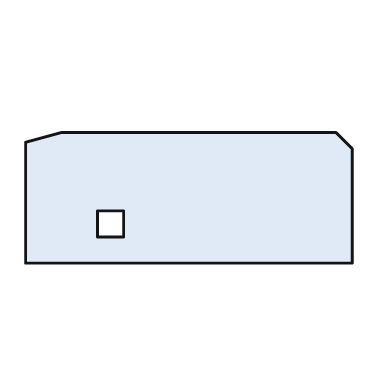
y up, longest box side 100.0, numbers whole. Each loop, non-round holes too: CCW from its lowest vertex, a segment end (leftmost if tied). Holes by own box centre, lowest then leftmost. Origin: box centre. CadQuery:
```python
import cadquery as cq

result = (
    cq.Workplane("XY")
    .moveTo(-50.0, -20.0)
    .lineTo(50.0, -20.0)
    .lineTo(50.0, 15.0)
    .lineTo(45.0, 20.0)
    .lineTo(-39.0, 20.0)
    .lineTo(-50.0, 17.0)
    .close()
    .moveTo(-28.0, -12.0)
    .lineTo(-20.0, -12.0)
    .lineTo(-20.0, -4.0)
    .lineTo(-28.0, -4.0)
    .close()
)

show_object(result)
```